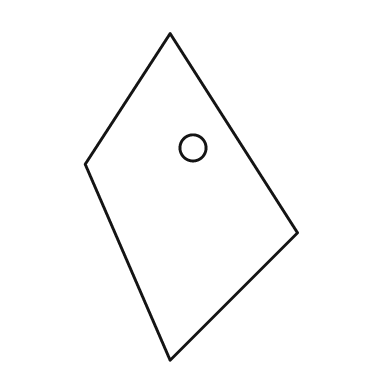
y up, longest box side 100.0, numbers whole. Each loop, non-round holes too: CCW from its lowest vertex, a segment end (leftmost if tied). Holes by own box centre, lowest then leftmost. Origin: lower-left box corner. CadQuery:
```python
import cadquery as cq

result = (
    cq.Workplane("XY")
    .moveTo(26.0, 0.0)
    .lineTo(65.0, 39.0)
    .lineTo(26.0, 100.0)
    .lineTo(0.0, 60.0)
    .close()
    .moveTo(33.0, 65.0)
    .circle(4.0)
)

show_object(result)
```